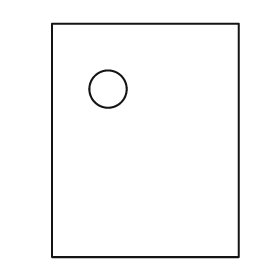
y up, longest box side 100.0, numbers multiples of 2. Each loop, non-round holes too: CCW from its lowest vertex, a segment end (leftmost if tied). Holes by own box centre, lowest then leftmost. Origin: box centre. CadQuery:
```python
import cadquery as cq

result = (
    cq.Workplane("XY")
    .moveTo(-40.0, -50.0)
    .lineTo(40.0, -50.0)
    .lineTo(40.0, 50.0)
    .lineTo(-40.0, 50.0)
    .close()
    .moveTo(-16.0, 22.0)
    .circle(8.0)
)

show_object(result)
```